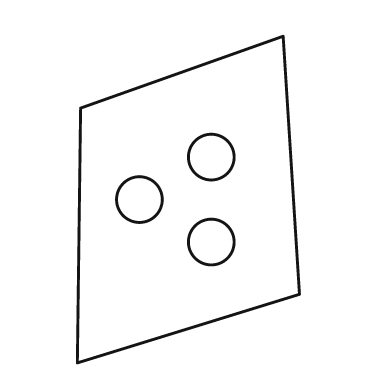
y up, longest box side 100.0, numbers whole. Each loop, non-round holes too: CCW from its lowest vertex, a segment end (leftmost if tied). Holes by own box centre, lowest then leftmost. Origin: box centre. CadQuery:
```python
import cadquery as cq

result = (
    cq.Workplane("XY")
    .moveTo(-34.0, -50.0)
    .lineTo(34.0, -29.0)
    .lineTo(29.0, 50.0)
    .lineTo(-33.0, 28.0)
    .close()
    .moveTo(7.0, -13.0)
    .circle(7.0)
    .moveTo(-15.0, 0.0)
    .circle(7.0)
    .moveTo(7.0, 13.0)
    .circle(7.0)
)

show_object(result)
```